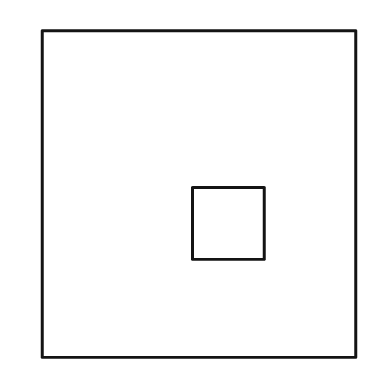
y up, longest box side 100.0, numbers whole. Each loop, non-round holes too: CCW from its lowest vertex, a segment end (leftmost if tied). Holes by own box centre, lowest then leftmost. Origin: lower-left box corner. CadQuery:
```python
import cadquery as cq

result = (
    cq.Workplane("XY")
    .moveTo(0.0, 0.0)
    .lineTo(96.0, 0.0)
    .lineTo(96.0, 100.0)
    .lineTo(0.0, 100.0)
    .close()
    .moveTo(46.0, 30.0)
    .lineTo(68.0, 30.0)
    .lineTo(68.0, 52.0)
    .lineTo(46.0, 52.0)
    .close()
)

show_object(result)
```